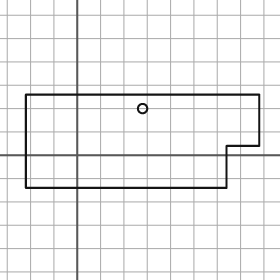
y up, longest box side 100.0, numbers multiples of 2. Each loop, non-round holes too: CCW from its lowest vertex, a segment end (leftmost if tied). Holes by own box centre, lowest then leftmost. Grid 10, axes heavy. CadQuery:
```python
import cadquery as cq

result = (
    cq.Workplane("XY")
    .moveTo(-22.0, -14.0)
    .lineTo(64.0, -14.0)
    .lineTo(64.0, 4.0)
    .lineTo(78.0, 4.0)
    .lineTo(78.0, 26.0)
    .lineTo(-22.0, 26.0)
    .close()
    .moveTo(28.0, 20.0)
    .circle(2.0)
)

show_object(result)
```